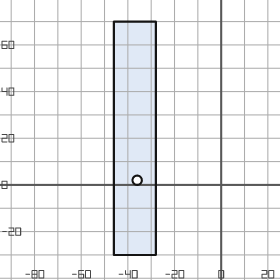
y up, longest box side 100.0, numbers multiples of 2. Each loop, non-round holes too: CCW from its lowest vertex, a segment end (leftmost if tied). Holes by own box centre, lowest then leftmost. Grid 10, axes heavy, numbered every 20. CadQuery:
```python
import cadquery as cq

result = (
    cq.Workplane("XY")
    .moveTo(-46.0, -30.0)
    .lineTo(-28.0, -30.0)
    .lineTo(-28.0, 70.0)
    .lineTo(-46.0, 70.0)
    .close()
    .moveTo(-36.0, 2.0)
    .circle(2.0)
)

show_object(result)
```